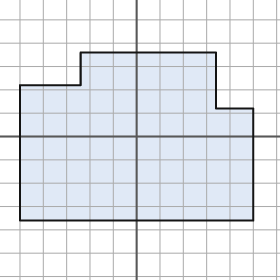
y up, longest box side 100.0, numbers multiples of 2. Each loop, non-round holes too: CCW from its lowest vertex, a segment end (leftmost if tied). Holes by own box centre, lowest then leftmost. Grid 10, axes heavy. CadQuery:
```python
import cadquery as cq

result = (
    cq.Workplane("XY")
    .moveTo(-50.0, -36.0)
    .lineTo(50.0, -36.0)
    .lineTo(50.0, 12.0)
    .lineTo(34.0, 12.0)
    .lineTo(34.0, 36.0)
    .lineTo(-24.0, 36.0)
    .lineTo(-24.0, 22.0)
    .lineTo(-50.0, 22.0)
    .close()
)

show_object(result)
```